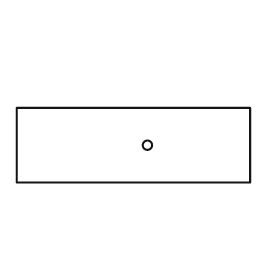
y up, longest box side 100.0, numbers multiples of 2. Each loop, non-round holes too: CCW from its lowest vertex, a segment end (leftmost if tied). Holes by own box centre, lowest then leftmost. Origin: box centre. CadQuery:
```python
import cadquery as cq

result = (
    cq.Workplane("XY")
    .moveTo(-50.0, -16.0)
    .lineTo(50.0, -16.0)
    .lineTo(50.0, 16.0)
    .lineTo(-50.0, 16.0)
    .close()
    .moveTo(6.0, 0.0)
    .circle(2.0)
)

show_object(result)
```